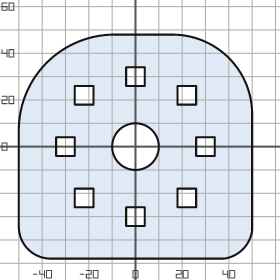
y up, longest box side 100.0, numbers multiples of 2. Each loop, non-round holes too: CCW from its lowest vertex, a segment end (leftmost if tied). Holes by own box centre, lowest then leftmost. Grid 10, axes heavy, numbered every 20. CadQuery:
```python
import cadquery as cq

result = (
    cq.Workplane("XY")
    .moveTo(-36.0, -48.0)
    .lineTo(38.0, -48.0)
    .threePointArc((46.0, -44.0), (50.0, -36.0))
    .lineTo(50.0, 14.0)
    .threePointArc((40.0, 38.0), (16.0, 48.0))
    .lineTo(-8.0, 48.0)
    .threePointArc((-38.0, 36.0), (-50.0, 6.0))
    .lineTo(-50.0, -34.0)
    .threePointArc((-46.0, -44.0), (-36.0, -48.0))
    .close()
    .moveTo(-4.0, -34.0)
    .lineTo(4.0, -34.0)
    .lineTo(4.0, -26.0)
    .lineTo(-4.0, -26.0)
    .close()
    .moveTo(-26.0, -26.0)
    .lineTo(-18.0, -26.0)
    .lineTo(-18.0, -18.0)
    .lineTo(-26.0, -18.0)
    .close()
    .moveTo(18.0, -26.0)
    .lineTo(26.0, -26.0)
    .lineTo(26.0, -18.0)
    .lineTo(18.0, -18.0)
    .close()
    .moveTo(-34.0, -4.0)
    .lineTo(-26.0, -4.0)
    .lineTo(-26.0, 4.0)
    .lineTo(-34.0, 4.0)
    .close()
    .moveTo(0.0, 0.0)
    .circle(10.0)
    .moveTo(26.0, -4.0)
    .lineTo(34.0, -4.0)
    .lineTo(34.0, 4.0)
    .lineTo(26.0, 4.0)
    .close()
    .moveTo(-26.0, 18.0)
    .lineTo(-18.0, 18.0)
    .lineTo(-18.0, 26.0)
    .lineTo(-26.0, 26.0)
    .close()
    .moveTo(18.0, 18.0)
    .lineTo(26.0, 18.0)
    .lineTo(26.0, 26.0)
    .lineTo(18.0, 26.0)
    .close()
    .moveTo(-4.0, 26.0)
    .lineTo(4.0, 26.0)
    .lineTo(4.0, 34.0)
    .lineTo(-4.0, 34.0)
    .close()
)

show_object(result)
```